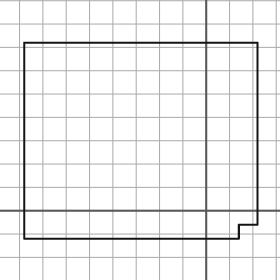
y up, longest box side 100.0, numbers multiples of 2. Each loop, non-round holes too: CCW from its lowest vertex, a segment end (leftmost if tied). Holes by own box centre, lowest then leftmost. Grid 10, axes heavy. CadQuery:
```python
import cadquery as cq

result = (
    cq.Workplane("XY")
    .moveTo(-78.0, -12.0)
    .lineTo(14.0, -12.0)
    .lineTo(14.0, -6.0)
    .lineTo(22.0, -6.0)
    .lineTo(22.0, 72.0)
    .lineTo(-78.0, 72.0)
    .close()
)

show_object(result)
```